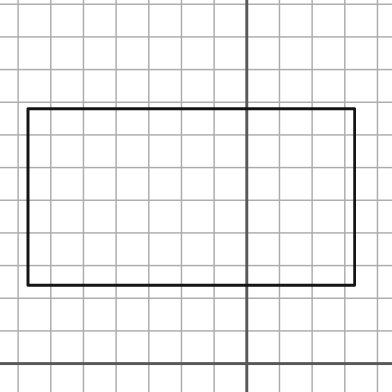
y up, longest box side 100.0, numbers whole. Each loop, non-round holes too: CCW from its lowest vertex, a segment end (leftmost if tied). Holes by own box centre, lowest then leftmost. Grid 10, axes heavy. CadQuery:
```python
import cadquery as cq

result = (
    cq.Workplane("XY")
    .moveTo(-67.0, 24.0)
    .lineTo(33.0, 24.0)
    .lineTo(33.0, 78.0)
    .lineTo(-67.0, 78.0)
    .close()
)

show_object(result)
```